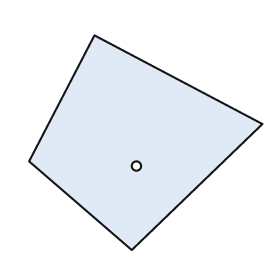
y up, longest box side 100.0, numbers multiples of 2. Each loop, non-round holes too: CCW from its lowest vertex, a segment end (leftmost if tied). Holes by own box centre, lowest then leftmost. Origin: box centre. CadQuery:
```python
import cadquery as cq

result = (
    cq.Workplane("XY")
    .moveTo(-6.0, -46.0)
    .lineTo(50.0, 8.0)
    .lineTo(-22.0, 46.0)
    .lineTo(-50.0, -8.0)
    .close()
    .moveTo(-4.0, -10.0)
    .circle(2.0)
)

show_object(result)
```